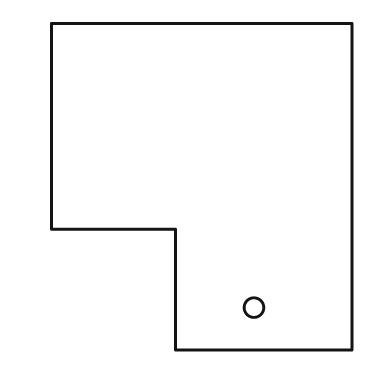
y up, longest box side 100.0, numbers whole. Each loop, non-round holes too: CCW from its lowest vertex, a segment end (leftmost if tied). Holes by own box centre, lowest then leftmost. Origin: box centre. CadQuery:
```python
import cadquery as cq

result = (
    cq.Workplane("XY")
    .moveTo(-8.0, -50.0)
    .lineTo(46.0, -50.0)
    .lineTo(46.0, 50.0)
    .lineTo(-46.0, 50.0)
    .lineTo(-46.0, -13.0)
    .lineTo(-8.0, -13.0)
    .close()
    .moveTo(16.0, -37.0)
    .circle(3.0)
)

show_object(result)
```